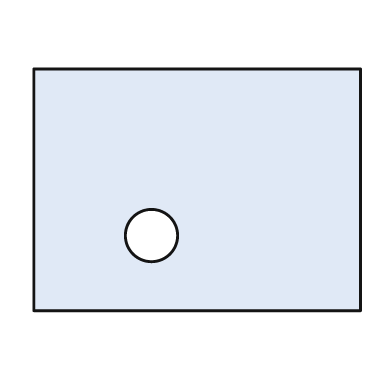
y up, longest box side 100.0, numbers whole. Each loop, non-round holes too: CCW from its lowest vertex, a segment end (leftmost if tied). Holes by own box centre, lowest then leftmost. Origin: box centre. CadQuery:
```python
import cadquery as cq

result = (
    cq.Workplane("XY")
    .moveTo(-50.0, -37.0)
    .lineTo(50.0, -37.0)
    .lineTo(50.0, 37.0)
    .lineTo(-50.0, 37.0)
    .close()
    .moveTo(-14.0, -14.0)
    .circle(8.0)
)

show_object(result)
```